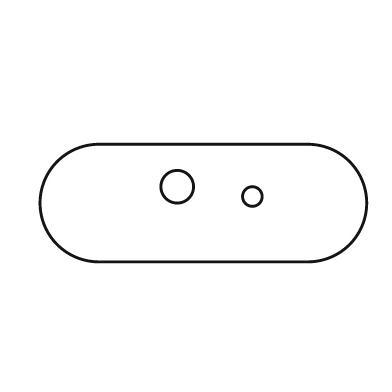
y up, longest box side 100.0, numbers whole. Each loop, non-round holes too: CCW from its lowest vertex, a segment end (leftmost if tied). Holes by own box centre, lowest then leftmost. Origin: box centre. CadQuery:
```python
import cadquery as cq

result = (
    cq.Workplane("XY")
    .moveTo(-32.0, -18.0)
    .lineTo(32.0, -18.0)
    .threePointArc((50.0, 0.0), (32.0, 18.0))
    .lineTo(-32.0, 18.0)
    .threePointArc((-50.0, 0.0), (-32.0, -18.0))
    .close()
    .moveTo(15.0, 2.0)
    .circle(3.0)
    .moveTo(-8.0, 5.0)
    .circle(5.0)
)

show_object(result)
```